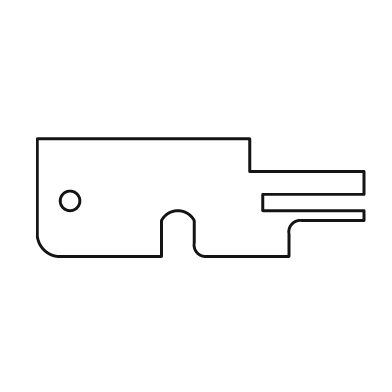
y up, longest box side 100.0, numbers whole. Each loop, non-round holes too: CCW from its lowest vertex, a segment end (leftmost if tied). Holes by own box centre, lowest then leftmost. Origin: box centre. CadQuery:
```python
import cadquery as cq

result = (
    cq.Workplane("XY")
    .moveTo(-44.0, -18.0)
    .lineTo(-12.0, -18.0)
    .lineTo(-12.0, -7.0)
    .threePointArc((-7.0, -4.0), (-2.0, -7.0))
    .lineTo(-2.0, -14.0)
    .threePointArc((-1.0, -17.0), (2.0, -18.0))
    .lineTo(27.0, -18.0)
    .lineTo(27.0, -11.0)
    .threePointArc((28.0, -8.0), (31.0, -7.0))
    .lineTo(50.0, -7.0)
    .lineTo(50.0, -4.0)
    .lineTo(19.0, -4.0)
    .lineTo(19.0, 1.0)
    .lineTo(50.0, 1.0)
    .lineTo(50.0, 8.0)
    .lineTo(15.0, 8.0)
    .lineTo(15.0, 18.0)
    .lineTo(-50.0, 18.0)
    .lineTo(-50.0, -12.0)
    .threePointArc((-48.0, -16.0), (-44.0, -18.0))
    .close()
    .moveTo(-40.0, -1.0)
    .circle(3.0)
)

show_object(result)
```